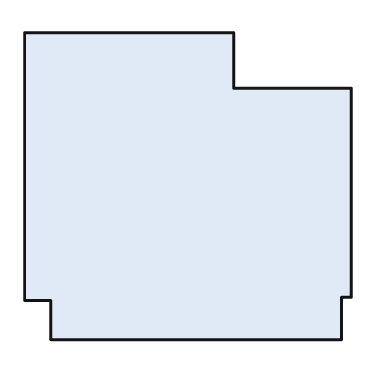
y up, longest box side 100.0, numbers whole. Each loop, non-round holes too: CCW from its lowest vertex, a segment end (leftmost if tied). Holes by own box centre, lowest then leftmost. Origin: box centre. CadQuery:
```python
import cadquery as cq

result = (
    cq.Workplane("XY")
    .moveTo(-42.0, -47.0)
    .lineTo(47.0, -47.0)
    .lineTo(47.0, -34.0)
    .lineTo(50.0, -34.0)
    .lineTo(50.0, 30.0)
    .lineTo(14.0, 30.0)
    .lineTo(14.0, 47.0)
    .lineTo(-50.0, 47.0)
    .lineTo(-50.0, -35.0)
    .lineTo(-42.0, -35.0)
    .close()
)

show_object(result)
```